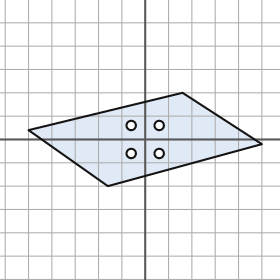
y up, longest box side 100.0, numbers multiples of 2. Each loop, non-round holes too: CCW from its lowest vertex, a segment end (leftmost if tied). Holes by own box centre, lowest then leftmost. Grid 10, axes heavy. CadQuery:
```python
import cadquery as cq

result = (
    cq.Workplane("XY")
    .moveTo(-16.0, -20.0)
    .lineTo(50.0, -2.0)
    .lineTo(16.0, 20.0)
    .lineTo(-50.0, 4.0)
    .close()
    .moveTo(-6.0, -6.0)
    .circle(2.0)
    .moveTo(6.0, -6.0)
    .circle(2.0)
    .moveTo(-6.0, 6.0)
    .circle(2.0)
    .moveTo(6.0, 6.0)
    .circle(2.0)
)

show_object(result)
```